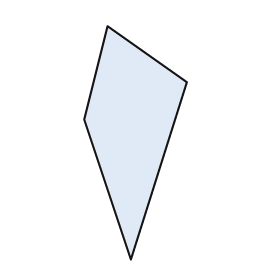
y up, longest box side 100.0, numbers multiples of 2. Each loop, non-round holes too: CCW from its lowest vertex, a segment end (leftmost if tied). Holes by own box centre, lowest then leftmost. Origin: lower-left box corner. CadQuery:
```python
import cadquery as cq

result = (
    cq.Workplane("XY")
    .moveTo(20.0, 0.0)
    .lineTo(44.0, 76.0)
    .lineTo(10.0, 100.0)
    .lineTo(0.0, 60.0)
    .close()
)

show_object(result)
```